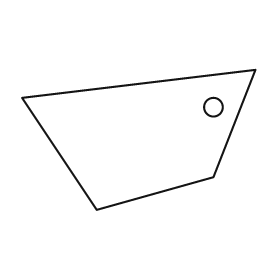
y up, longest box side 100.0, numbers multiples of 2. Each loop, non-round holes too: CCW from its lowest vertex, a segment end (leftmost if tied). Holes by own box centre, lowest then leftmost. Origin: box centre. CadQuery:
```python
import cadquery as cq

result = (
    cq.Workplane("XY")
    .moveTo(-18.0, -30.0)
    .lineTo(32.0, -16.0)
    .lineTo(50.0, 30.0)
    .lineTo(-50.0, 18.0)
    .close()
    .moveTo(32.0, 14.0)
    .circle(4.0)
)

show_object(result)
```